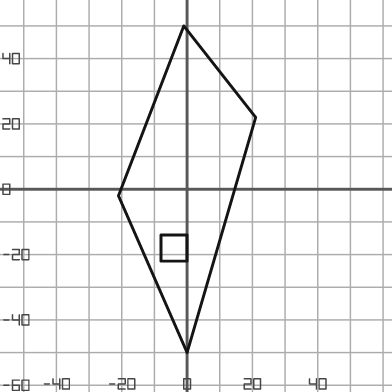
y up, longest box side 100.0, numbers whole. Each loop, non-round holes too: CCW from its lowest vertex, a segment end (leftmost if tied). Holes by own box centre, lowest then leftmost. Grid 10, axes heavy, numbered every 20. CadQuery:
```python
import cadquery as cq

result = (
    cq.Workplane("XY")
    .moveTo(0.0, -50.0)
    .lineTo(21.0, 22.0)
    .lineTo(-1.0, 50.0)
    .lineTo(-21.0, -2.0)
    .close()
    .moveTo(-8.0, -22.0)
    .lineTo(0.0, -22.0)
    .lineTo(0.0, -14.0)
    .lineTo(-8.0, -14.0)
    .close()
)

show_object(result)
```